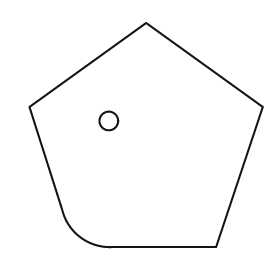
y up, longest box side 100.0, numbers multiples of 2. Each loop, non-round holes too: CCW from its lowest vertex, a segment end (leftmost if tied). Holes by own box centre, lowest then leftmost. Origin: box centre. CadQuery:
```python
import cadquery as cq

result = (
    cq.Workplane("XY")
    .moveTo(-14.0, -48.0)
    .lineTo(30.0, -48.0)
    .lineTo(50.0, 12.0)
    .lineTo(0.0, 48.0)
    .lineTo(-50.0, 12.0)
    .lineTo(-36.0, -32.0)
    .threePointArc((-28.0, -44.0), (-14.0, -48.0))
    .close()
    .moveTo(-16.0, 6.0)
    .circle(4.0)
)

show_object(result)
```